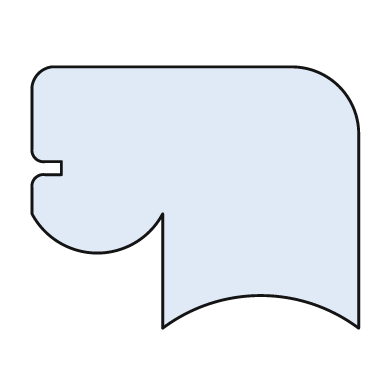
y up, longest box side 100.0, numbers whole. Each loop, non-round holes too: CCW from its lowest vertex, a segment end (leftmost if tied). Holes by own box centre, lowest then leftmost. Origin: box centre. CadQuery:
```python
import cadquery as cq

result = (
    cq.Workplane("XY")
    .moveTo(-10.0, -40.0)
    .threePointArc((20.0, -30.0), (50.0, -40.0))
    .lineTo(50.0, 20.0)
    .threePointArc((44.0, 34.0), (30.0, 40.0))
    .lineTo(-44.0, 40.0)
    .threePointArc((-48.0, 38.0), (-50.0, 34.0))
    .lineTo(-50.0, 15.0)
    .threePointArc((-49.0, 12.0), (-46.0, 11.0))
    .lineTo(-41.0, 11.0)
    .lineTo(-41.0, 7.0)
    .lineTo(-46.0, 7.0)
    .threePointArc((-49.0, 6.0), (-50.0, 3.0))
    .lineTo(-50.0, -5.0)
    .threePointArc((-30.0, -17.0), (-10.0, -5.0))
    .close()
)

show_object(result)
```